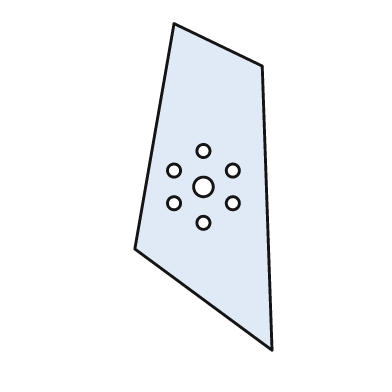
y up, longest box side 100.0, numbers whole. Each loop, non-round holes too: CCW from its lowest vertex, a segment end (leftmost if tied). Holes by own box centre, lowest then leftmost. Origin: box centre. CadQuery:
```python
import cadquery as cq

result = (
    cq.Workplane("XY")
    .moveTo(21.0, -50.0)
    .lineTo(18.0, 37.0)
    .lineTo(-9.0, 50.0)
    .lineTo(-21.0, -19.0)
    .close()
    .moveTo(0.0, -11.0)
    .circle(2.0)
    .moveTo(-9.0, -5.0)
    .circle(2.0)
    .moveTo(9.0, -5.0)
    .circle(2.0)
    .moveTo(0.0, 0.0)
    .circle(3.0)
    .moveTo(-9.0, 5.0)
    .circle(2.0)
    .moveTo(9.0, 5.0)
    .circle(2.0)
    .moveTo(0.0, 11.0)
    .circle(2.0)
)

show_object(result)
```